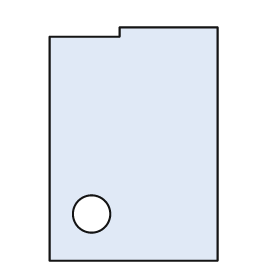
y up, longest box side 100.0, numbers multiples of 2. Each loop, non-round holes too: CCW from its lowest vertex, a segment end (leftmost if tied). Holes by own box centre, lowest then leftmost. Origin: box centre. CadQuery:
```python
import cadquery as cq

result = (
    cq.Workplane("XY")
    .moveTo(-36.0, -50.0)
    .lineTo(36.0, -50.0)
    .lineTo(36.0, 50.0)
    .lineTo(-6.0, 50.0)
    .lineTo(-6.0, 46.0)
    .lineTo(-36.0, 46.0)
    .close()
    .moveTo(-18.0, -30.0)
    .circle(8.0)
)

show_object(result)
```